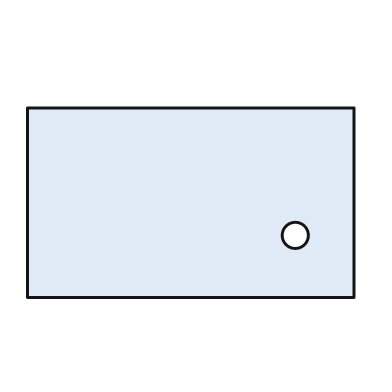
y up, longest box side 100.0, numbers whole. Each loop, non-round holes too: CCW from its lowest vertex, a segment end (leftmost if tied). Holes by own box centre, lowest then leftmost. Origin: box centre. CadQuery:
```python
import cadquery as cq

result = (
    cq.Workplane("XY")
    .moveTo(-50.0, -29.0)
    .lineTo(50.0, -29.0)
    .lineTo(50.0, 29.0)
    .lineTo(-50.0, 29.0)
    .close()
    .moveTo(32.0, -10.0)
    .circle(4.0)
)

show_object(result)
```